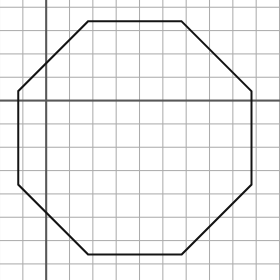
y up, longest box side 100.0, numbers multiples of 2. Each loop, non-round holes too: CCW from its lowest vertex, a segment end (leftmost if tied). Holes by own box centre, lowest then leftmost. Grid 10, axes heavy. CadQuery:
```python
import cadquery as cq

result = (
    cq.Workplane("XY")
    .moveTo(18.0, -66.0)
    .lineTo(58.0, -66.0)
    .lineTo(88.0, -36.0)
    .lineTo(88.0, 4.0)
    .lineTo(58.0, 34.0)
    .lineTo(18.0, 34.0)
    .lineTo(-12.0, 4.0)
    .lineTo(-12.0, -36.0)
    .close()
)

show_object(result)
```